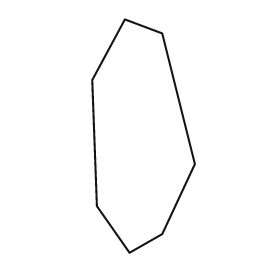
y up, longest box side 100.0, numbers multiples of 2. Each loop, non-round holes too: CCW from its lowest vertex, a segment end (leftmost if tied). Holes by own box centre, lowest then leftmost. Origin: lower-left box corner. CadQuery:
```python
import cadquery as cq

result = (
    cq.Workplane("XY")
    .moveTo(16.0, 0.0)
    .lineTo(30.0, 8.0)
    .lineTo(44.0, 38.0)
    .lineTo(30.0, 94.0)
    .lineTo(14.0, 100.0)
    .lineTo(0.0, 74.0)
    .lineTo(2.0, 20.0)
    .close()
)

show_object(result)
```